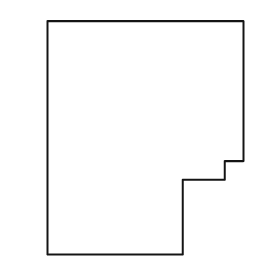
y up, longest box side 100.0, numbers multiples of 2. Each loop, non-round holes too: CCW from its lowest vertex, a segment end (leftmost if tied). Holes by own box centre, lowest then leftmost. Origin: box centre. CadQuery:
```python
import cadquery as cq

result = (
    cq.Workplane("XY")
    .moveTo(-42.0, -50.0)
    .lineTo(16.0, -50.0)
    .lineTo(16.0, -18.0)
    .lineTo(34.0, -18.0)
    .lineTo(34.0, -10.0)
    .lineTo(42.0, -10.0)
    .lineTo(42.0, 50.0)
    .lineTo(-42.0, 50.0)
    .close()
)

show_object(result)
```